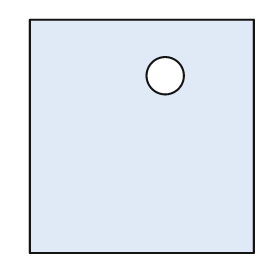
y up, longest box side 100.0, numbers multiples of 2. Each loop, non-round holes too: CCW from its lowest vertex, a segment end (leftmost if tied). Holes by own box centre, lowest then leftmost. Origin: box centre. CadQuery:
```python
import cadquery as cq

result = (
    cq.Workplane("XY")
    .moveTo(-48.0, -50.0)
    .lineTo(48.0, -50.0)
    .lineTo(48.0, 50.0)
    .lineTo(-48.0, 50.0)
    .close()
    .moveTo(10.0, 26.0)
    .circle(8.0)
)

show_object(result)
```